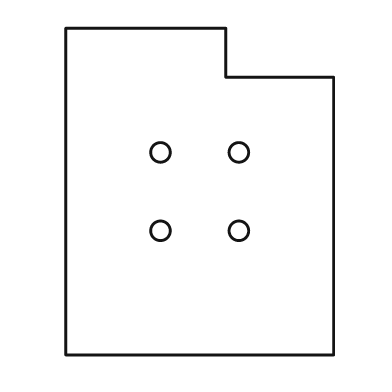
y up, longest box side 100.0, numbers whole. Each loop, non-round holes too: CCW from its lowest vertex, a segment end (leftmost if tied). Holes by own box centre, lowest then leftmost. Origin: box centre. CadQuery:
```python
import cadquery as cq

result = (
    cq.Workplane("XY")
    .moveTo(-41.0, -50.0)
    .lineTo(41.0, -50.0)
    .lineTo(41.0, 35.0)
    .lineTo(8.0, 35.0)
    .lineTo(8.0, 50.0)
    .lineTo(-41.0, 50.0)
    .close()
    .moveTo(-12.0, -12.0)
    .circle(3.0)
    .moveTo(12.0, -12.0)
    .circle(3.0)
    .moveTo(-12.0, 12.0)
    .circle(3.0)
    .moveTo(12.0, 12.0)
    .circle(3.0)
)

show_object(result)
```